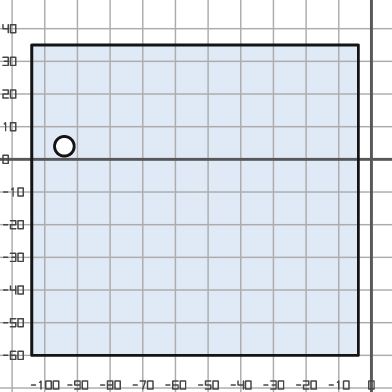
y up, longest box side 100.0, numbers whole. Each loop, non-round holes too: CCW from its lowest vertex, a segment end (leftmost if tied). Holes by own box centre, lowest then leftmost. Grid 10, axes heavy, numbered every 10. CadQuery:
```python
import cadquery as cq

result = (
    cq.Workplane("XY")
    .moveTo(-104.0, -60.0)
    .lineTo(-4.0, -60.0)
    .lineTo(-4.0, 35.0)
    .lineTo(-104.0, 35.0)
    .close()
    .moveTo(-94.0, 4.0)
    .circle(3.0)
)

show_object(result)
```